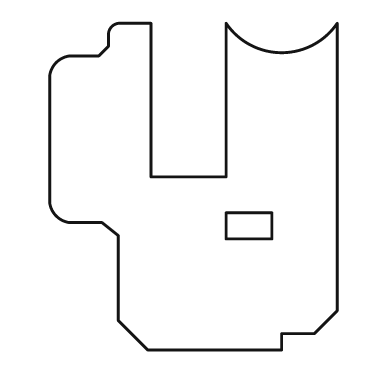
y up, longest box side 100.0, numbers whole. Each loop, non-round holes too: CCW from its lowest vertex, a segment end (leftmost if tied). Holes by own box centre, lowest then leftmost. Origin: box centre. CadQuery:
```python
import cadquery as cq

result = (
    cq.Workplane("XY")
    .moveTo(-14.0, -50.0)
    .lineTo(27.0, -50.0)
    .lineTo(27.0, -45.0)
    .lineTo(37.0, -45.0)
    .lineTo(44.0, -38.0)
    .lineTo(44.0, 50.0)
    .threePointArc((27.0, 41.0), (10.0, 50.0))
    .lineTo(10.0, 3.0)
    .lineTo(-13.0, 3.0)
    .lineTo(-13.0, 50.0)
    .lineTo(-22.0, 50.0)
    .threePointArc((-25.0, 49.0), (-26.0, 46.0))
    .lineTo(-26.0, 43.0)
    .lineTo(-29.0, 40.0)
    .lineTo(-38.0, 40.0)
    .threePointArc((-42.0, 38.0), (-44.0, 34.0))
    .lineTo(-44.0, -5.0)
    .threePointArc((-42.0, -9.0), (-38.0, -11.0))
    .lineTo(-28.0, -11.0)
    .lineTo(-23.0, -15.0)
    .lineTo(-23.0, -41.0)
    .close()
    .moveTo(10.0, -16.0)
    .lineTo(24.0, -16.0)
    .lineTo(24.0, -8.0)
    .lineTo(10.0, -8.0)
    .close()
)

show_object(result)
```